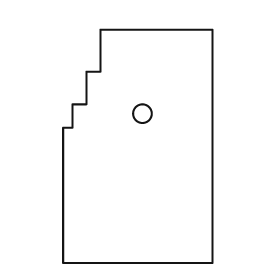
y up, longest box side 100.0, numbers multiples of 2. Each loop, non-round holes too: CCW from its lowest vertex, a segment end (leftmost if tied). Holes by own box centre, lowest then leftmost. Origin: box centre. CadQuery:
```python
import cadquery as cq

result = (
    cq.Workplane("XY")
    .moveTo(-32.0, -50.0)
    .lineTo(32.0, -50.0)
    .lineTo(32.0, 50.0)
    .lineTo(-16.0, 50.0)
    .lineTo(-16.0, 32.0)
    .lineTo(-22.0, 32.0)
    .lineTo(-22.0, 18.0)
    .lineTo(-28.0, 18.0)
    .lineTo(-28.0, 8.0)
    .lineTo(-32.0, 8.0)
    .close()
    .moveTo(2.0, 14.0)
    .circle(4.0)
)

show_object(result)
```